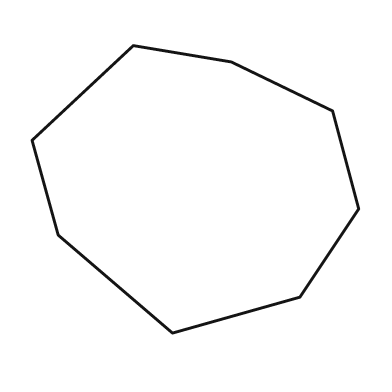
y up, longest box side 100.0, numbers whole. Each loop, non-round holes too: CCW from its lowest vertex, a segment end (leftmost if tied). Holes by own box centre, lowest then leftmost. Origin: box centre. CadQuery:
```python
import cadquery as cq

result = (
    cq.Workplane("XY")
    .moveTo(-7.0, -44.0)
    .lineTo(32.0, -33.0)
    .lineTo(50.0, -6.0)
    .lineTo(42.0, 24.0)
    .lineTo(11.0, 39.0)
    .lineTo(-19.0, 44.0)
    .lineTo(-50.0, 15.0)
    .lineTo(-42.0, -14.0)
    .close()
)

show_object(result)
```